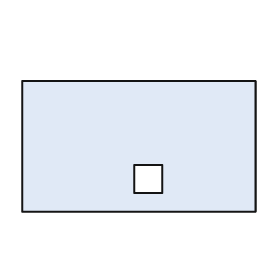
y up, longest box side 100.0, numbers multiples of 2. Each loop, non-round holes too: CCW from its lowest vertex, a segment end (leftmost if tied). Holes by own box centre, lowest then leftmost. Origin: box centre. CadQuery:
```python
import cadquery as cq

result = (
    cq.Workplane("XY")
    .moveTo(-50.0, -28.0)
    .lineTo(50.0, -28.0)
    .lineTo(50.0, 28.0)
    .lineTo(-50.0, 28.0)
    .close()
    .moveTo(-2.0, -20.0)
    .lineTo(10.0, -20.0)
    .lineTo(10.0, -8.0)
    .lineTo(-2.0, -8.0)
    .close()
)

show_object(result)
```